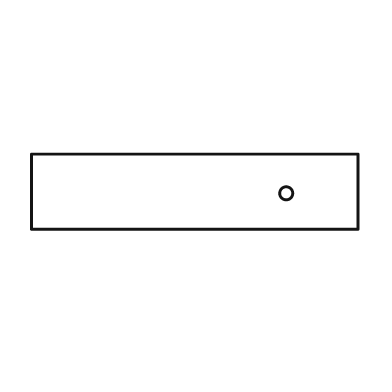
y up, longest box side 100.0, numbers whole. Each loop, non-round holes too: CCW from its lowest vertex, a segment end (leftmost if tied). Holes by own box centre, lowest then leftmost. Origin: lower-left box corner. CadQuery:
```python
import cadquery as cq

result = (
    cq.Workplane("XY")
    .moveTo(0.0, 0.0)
    .lineTo(100.0, 0.0)
    .lineTo(100.0, 23.0)
    .lineTo(0.0, 23.0)
    .close()
    .moveTo(78.0, 11.0)
    .circle(2.0)
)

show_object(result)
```